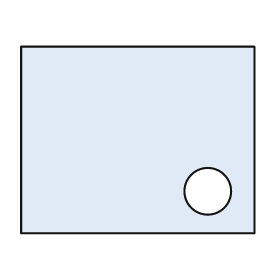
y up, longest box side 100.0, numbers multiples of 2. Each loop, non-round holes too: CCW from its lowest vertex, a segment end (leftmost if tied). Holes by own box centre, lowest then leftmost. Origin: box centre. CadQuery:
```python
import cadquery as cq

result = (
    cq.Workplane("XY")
    .moveTo(-50.0, -40.0)
    .lineTo(50.0, -40.0)
    .lineTo(50.0, 40.0)
    .lineTo(-50.0, 40.0)
    .close()
    .moveTo(30.0, -22.0)
    .circle(10.0)
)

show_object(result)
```